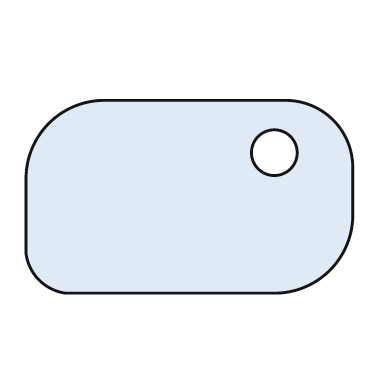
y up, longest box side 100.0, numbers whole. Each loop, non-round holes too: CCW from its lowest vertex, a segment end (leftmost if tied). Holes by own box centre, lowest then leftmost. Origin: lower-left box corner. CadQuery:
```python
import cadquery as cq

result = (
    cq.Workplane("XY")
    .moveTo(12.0, 0.0)
    .lineTo(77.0, 0.0)
    .threePointArc((93.0, 7.0), (100.0, 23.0))
    .lineTo(100.0, 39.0)
    .threePointArc((94.0, 53.0), (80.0, 59.0))
    .lineTo(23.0, 59.0)
    .threePointArc((7.0, 52.0), (0.0, 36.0))
    .lineTo(0.0, 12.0)
    .threePointArc((4.0, 4.0), (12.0, 0.0))
    .close()
    .moveTo(76.0, 43.0)
    .circle(7.0)
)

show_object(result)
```